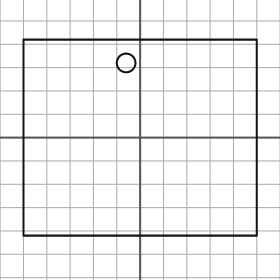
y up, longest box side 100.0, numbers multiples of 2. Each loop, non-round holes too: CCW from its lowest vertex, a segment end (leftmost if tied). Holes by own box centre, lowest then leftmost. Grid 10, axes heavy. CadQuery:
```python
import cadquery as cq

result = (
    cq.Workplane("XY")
    .moveTo(-50.0, -42.0)
    .lineTo(50.0, -42.0)
    .lineTo(50.0, 42.0)
    .lineTo(-50.0, 42.0)
    .close()
    .moveTo(-6.0, 32.0)
    .circle(4.0)
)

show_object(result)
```